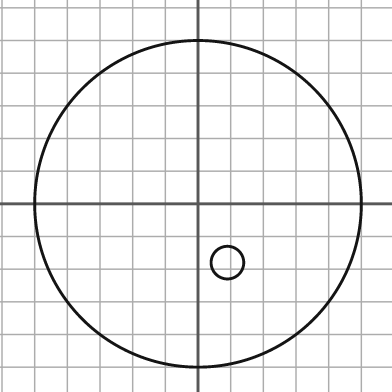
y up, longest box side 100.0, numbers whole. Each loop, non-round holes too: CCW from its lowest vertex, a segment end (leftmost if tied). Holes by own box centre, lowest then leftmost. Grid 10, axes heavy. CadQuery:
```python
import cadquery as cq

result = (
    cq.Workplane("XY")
    .moveTo(0.0, 0.0)
    .circle(50.0)
    .moveTo(9.0, -18.0)
    .circle(5.0)
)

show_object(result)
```